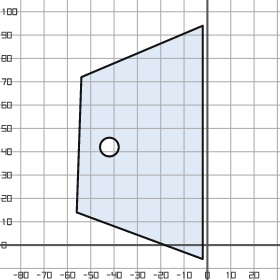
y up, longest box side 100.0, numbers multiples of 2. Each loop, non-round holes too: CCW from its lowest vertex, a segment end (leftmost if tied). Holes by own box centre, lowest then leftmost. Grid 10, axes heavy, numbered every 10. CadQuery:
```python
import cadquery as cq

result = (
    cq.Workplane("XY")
    .moveTo(-2.0, -6.0)
    .lineTo(-2.0, 94.0)
    .lineTo(-54.0, 72.0)
    .lineTo(-56.0, 14.0)
    .close()
    .moveTo(-42.0, 42.0)
    .circle(4.0)
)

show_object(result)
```